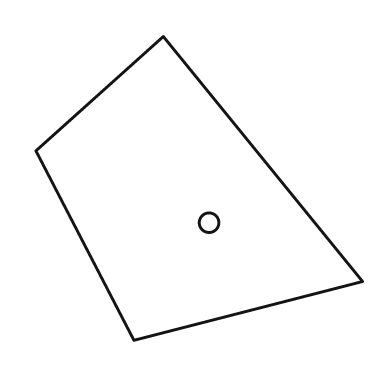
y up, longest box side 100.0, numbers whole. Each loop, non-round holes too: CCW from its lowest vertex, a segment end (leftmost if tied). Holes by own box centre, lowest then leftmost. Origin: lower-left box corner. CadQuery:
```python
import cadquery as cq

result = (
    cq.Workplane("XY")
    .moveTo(30.0, 0.0)
    .lineTo(100.0, 18.0)
    .lineTo(39.0, 93.0)
    .lineTo(0.0, 58.0)
    .close()
    .moveTo(53.0, 36.0)
    .circle(3.0)
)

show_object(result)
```